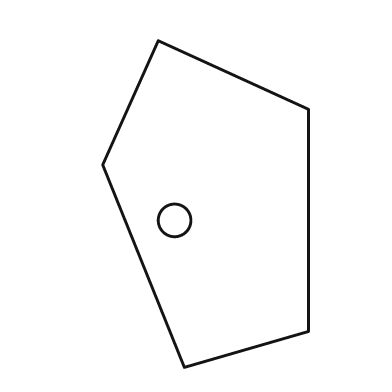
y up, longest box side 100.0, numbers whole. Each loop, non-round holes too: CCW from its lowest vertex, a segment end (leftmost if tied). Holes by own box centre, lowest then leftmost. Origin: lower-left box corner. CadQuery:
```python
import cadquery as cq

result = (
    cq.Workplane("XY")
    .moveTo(25.0, 0.0)
    .lineTo(63.0, 11.0)
    .lineTo(63.0, 79.0)
    .lineTo(17.0, 100.0)
    .lineTo(0.0, 62.0)
    .close()
    .moveTo(22.0, 45.0)
    .circle(5.0)
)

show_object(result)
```